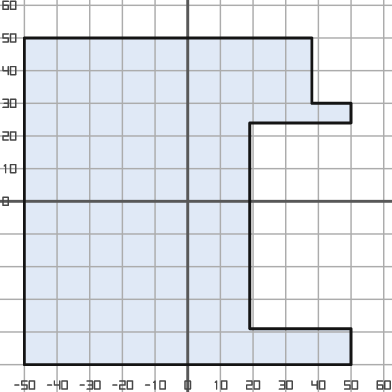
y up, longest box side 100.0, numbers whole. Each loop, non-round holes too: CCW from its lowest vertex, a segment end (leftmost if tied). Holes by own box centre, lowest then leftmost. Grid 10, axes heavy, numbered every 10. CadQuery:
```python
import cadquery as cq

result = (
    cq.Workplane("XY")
    .moveTo(-50.0, -50.0)
    .lineTo(50.0, -50.0)
    .lineTo(50.0, -39.0)
    .lineTo(19.0, -39.0)
    .lineTo(19.0, 24.0)
    .lineTo(50.0, 24.0)
    .lineTo(50.0, 30.0)
    .lineTo(38.0, 30.0)
    .lineTo(38.0, 50.0)
    .lineTo(-50.0, 50.0)
    .close()
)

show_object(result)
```